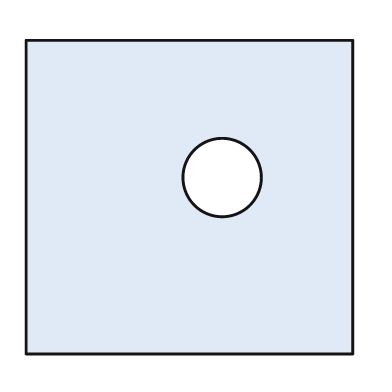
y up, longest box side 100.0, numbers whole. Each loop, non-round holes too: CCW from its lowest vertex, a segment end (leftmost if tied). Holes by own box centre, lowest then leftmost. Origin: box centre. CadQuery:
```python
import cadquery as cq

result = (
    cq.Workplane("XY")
    .moveTo(-50.0, -48.0)
    .lineTo(50.0, -48.0)
    .lineTo(50.0, 48.0)
    .lineTo(-50.0, 48.0)
    .close()
    .moveTo(10.0, 6.0)
    .circle(12.0)
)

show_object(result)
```